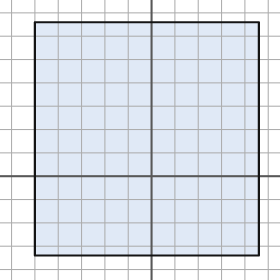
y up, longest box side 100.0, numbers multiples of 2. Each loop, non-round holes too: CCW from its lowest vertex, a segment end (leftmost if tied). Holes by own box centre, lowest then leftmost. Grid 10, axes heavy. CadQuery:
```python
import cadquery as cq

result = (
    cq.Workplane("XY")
    .moveTo(-50.0, -34.0)
    .lineTo(46.0, -34.0)
    .lineTo(46.0, 66.0)
    .lineTo(-50.0, 66.0)
    .close()
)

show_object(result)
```